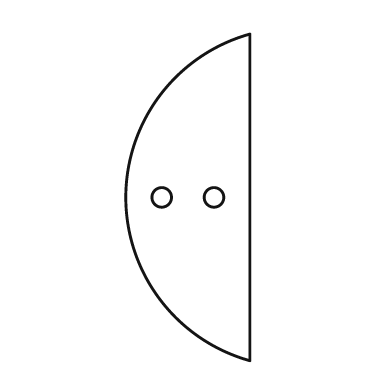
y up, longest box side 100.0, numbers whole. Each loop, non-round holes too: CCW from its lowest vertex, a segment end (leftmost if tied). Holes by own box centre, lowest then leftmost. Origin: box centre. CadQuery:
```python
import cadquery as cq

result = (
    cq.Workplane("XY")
    .moveTo(19.0, -50.0)
    .lineTo(19.0, 50.0)
    .threePointArc((-19.0, 0.0), (19.0, -50.0))
    .close()
    .moveTo(-8.0, 0.0)
    .circle(3.0)
    .moveTo(8.0, 0.0)
    .circle(3.0)
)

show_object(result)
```